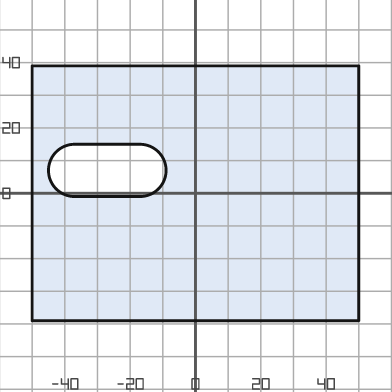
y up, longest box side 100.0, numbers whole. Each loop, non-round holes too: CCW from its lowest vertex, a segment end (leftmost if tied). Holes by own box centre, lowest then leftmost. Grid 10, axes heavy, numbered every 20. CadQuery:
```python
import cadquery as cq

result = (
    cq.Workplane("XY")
    .moveTo(-50.0, -39.0)
    .lineTo(50.0, -39.0)
    .lineTo(50.0, 39.0)
    .lineTo(-50.0, 39.0)
    .close()
    .moveTo(-37.0, -1.0)
    .lineTo(-17.0, -1.0)
    .threePointArc((-9.0, 7.0), (-17.0, 15.0))
    .lineTo(-37.0, 15.0)
    .threePointArc((-45.0, 7.0), (-37.0, -1.0))
    .close()
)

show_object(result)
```